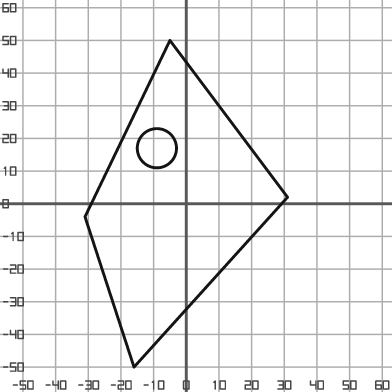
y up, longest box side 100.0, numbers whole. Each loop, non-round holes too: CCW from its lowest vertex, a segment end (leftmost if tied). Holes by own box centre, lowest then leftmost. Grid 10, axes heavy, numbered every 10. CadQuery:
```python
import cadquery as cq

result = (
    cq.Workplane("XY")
    .moveTo(-16.0, -50.0)
    .lineTo(31.0, 2.0)
    .lineTo(-5.0, 50.0)
    .lineTo(-31.0, -4.0)
    .close()
    .moveTo(-9.0, 17.0)
    .circle(6.0)
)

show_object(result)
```